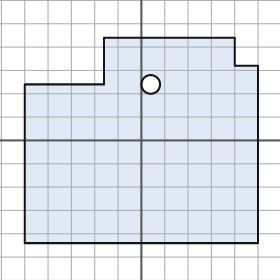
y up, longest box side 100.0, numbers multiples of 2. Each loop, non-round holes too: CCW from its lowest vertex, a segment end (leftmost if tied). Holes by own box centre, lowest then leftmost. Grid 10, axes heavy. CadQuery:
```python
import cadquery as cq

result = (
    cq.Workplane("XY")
    .moveTo(-50.0, -44.0)
    .lineTo(50.0, -44.0)
    .lineTo(50.0, 32.0)
    .lineTo(40.0, 32.0)
    .lineTo(40.0, 44.0)
    .lineTo(-16.0, 44.0)
    .lineTo(-16.0, 24.0)
    .lineTo(-50.0, 24.0)
    .close()
    .moveTo(4.0, 24.0)
    .circle(4.0)
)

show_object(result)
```